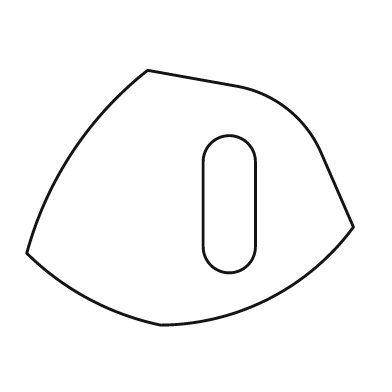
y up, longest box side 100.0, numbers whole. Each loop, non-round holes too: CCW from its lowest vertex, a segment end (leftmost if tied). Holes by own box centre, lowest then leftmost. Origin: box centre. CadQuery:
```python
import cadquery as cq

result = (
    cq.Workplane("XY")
    .moveTo(-9.0, -39.0)
    .threePointArc((24.0, -31.0), (50.0, -9.0))
    .lineTo(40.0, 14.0)
    .threePointArc((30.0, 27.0), (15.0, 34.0))
    .lineTo(-13.0, 39.0)
    .threePointArc((-36.0, 14.0), (-50.0, -17.0))
    .threePointArc((-31.0, -31.0), (-9.0, -39.0))
    .close()
    .moveTo(4.0, -15.0)
    .threePointArc((12.0, -23.0), (20.0, -15.0))
    .lineTo(20.0, 11.0)
    .threePointArc((12.0, 19.0), (4.0, 11.0))
    .close()
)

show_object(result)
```